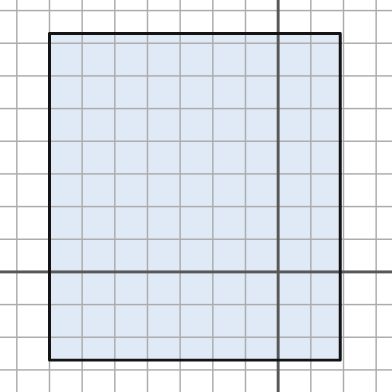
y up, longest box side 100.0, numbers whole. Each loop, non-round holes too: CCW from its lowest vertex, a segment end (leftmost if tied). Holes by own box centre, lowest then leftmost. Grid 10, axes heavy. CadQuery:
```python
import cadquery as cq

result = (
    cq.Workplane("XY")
    .moveTo(-70.0, -27.0)
    .lineTo(19.0, -27.0)
    .lineTo(19.0, 73.0)
    .lineTo(-70.0, 73.0)
    .close()
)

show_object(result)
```